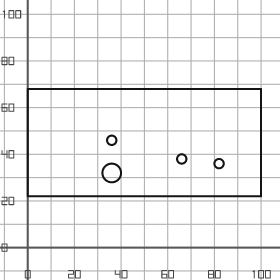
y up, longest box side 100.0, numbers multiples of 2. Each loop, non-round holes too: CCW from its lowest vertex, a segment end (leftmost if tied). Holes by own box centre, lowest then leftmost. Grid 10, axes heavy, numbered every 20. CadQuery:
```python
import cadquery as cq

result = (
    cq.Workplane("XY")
    .moveTo(0.0, 22.0)
    .lineTo(100.0, 22.0)
    .lineTo(100.0, 68.0)
    .lineTo(0.0, 68.0)
    .close()
    .moveTo(36.0, 32.0)
    .circle(4.0)
    .moveTo(82.0, 36.0)
    .circle(2.0)
    .moveTo(66.0, 38.0)
    .circle(2.0)
    .moveTo(36.0, 46.0)
    .circle(2.0)
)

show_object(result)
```